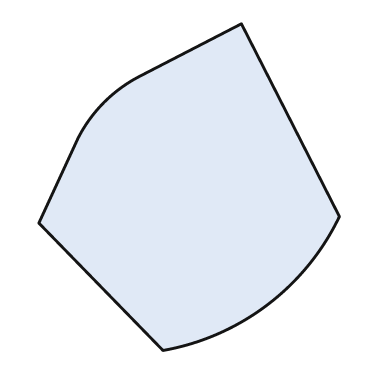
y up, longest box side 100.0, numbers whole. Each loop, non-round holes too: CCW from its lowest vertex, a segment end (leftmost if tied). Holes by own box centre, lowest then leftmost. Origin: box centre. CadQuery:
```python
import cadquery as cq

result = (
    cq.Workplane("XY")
    .moveTo(-8.0, -50.0)
    .threePointArc((24.0, -36.0), (46.0, -9.0))
    .lineTo(16.0, 50.0)
    .lineTo(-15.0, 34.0)
    .threePointArc((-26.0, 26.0), (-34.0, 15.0))
    .lineTo(-46.0, -11.0)
    .close()
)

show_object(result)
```